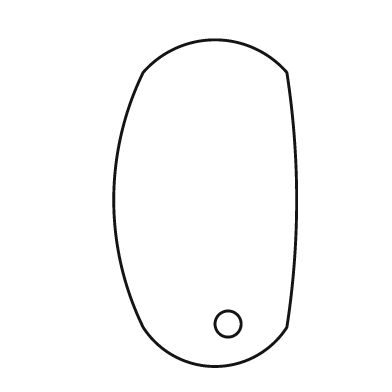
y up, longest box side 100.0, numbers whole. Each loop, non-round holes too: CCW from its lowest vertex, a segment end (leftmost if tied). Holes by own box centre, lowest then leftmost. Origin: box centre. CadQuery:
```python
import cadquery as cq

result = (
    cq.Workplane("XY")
    .moveTo(-19.0, -38.0)
    .threePointArc((3.0, -50.0), (25.0, -38.0))
    .threePointArc((28.0, 1.0), (25.0, 40.0))
    .threePointArc((3.0, 50.0), (-19.0, 40.0))
    .threePointArc((-28.0, 1.0), (-19.0, -38.0))
    .close()
    .moveTo(7.0, -37.0)
    .circle(4.0)
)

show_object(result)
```